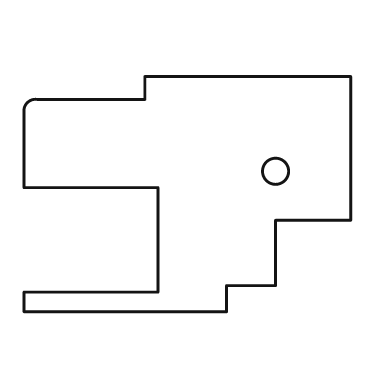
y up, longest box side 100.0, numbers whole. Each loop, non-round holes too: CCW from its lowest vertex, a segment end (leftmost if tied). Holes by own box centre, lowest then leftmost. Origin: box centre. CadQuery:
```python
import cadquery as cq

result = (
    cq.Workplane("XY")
    .moveTo(-50.0, -36.0)
    .lineTo(12.0, -36.0)
    .lineTo(12.0, -28.0)
    .lineTo(27.0, -28.0)
    .lineTo(27.0, -8.0)
    .lineTo(50.0, -8.0)
    .lineTo(50.0, 36.0)
    .lineTo(-13.0, 36.0)
    .lineTo(-13.0, 29.0)
    .lineTo(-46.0, 29.0)
    .threePointArc((-49.0, 28.0), (-50.0, 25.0))
    .lineTo(-50.0, 2.0)
    .lineTo(-9.0, 2.0)
    .lineTo(-9.0, -30.0)
    .lineTo(-50.0, -30.0)
    .close()
    .moveTo(27.0, 7.0)
    .circle(4.0)
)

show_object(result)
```